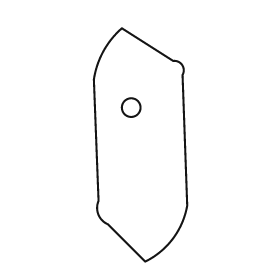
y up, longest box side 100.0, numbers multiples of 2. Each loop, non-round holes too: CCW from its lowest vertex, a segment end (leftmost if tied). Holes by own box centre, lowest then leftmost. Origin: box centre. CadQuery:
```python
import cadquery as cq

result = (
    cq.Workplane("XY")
    .moveTo(2.0, -50.0)
    .threePointArc((14.0, -40.0), (20.0, -26.0))
    .lineTo(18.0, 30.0)
    .threePointArc((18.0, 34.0), (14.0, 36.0))
    .lineTo(-8.0, 50.0)
    .threePointArc((-16.0, 40.0), (-20.0, 28.0))
    .lineTo(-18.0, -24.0)
    .threePointArc((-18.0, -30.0), (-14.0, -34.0))
    .close()
    .moveTo(-4.0, 16.0)
    .circle(4.0)
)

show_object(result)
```